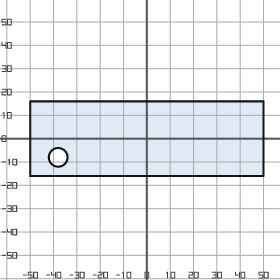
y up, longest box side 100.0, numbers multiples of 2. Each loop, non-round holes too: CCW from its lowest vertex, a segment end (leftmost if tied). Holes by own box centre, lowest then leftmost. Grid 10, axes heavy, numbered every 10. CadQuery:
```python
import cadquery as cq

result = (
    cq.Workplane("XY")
    .moveTo(-50.0, -16.0)
    .lineTo(50.0, -16.0)
    .lineTo(50.0, 16.0)
    .lineTo(-50.0, 16.0)
    .close()
    .moveTo(-38.0, -8.0)
    .circle(4.0)
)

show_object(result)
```